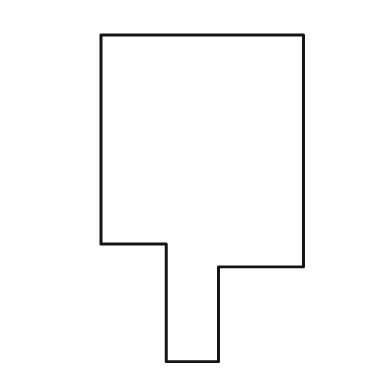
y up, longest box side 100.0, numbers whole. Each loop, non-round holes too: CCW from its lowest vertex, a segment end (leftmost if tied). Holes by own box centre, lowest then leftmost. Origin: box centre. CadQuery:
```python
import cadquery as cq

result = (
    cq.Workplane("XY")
    .moveTo(-11.0, -50.0)
    .lineTo(5.0, -50.0)
    .lineTo(5.0, -21.0)
    .lineTo(31.0, -21.0)
    .lineTo(31.0, 50.0)
    .lineTo(-31.0, 50.0)
    .lineTo(-31.0, -14.0)
    .lineTo(-11.0, -14.0)
    .close()
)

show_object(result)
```